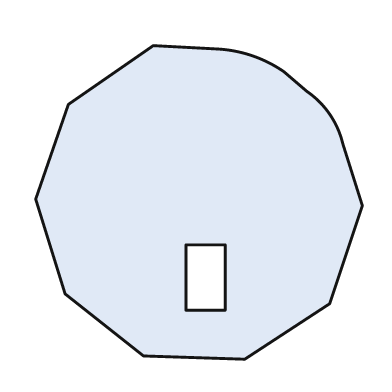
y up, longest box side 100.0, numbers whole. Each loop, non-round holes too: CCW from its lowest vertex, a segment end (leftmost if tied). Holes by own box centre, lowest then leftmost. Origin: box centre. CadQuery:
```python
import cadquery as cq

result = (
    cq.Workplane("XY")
    .moveTo(14.0, -48.0)
    .lineTo(40.0, -31.0)
    .lineTo(50.0, -1.0)
    .lineTo(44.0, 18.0)
    .threePointArc((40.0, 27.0), (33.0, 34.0))
    .lineTo(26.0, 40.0)
    .threePointArc((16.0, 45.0), (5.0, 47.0))
    .lineTo(-14.0, 48.0)
    .lineTo(-40.0, 30.0)
    .lineTo(-50.0, 1.0)
    .lineTo(-41.0, -28.0)
    .lineTo(-17.0, -47.0)
    .close()
    .moveTo(-4.0, -33.0)
    .lineTo(8.0, -33.0)
    .lineTo(8.0, -13.0)
    .lineTo(-4.0, -13.0)
    .close()
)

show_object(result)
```